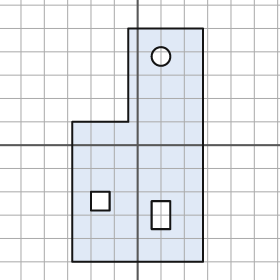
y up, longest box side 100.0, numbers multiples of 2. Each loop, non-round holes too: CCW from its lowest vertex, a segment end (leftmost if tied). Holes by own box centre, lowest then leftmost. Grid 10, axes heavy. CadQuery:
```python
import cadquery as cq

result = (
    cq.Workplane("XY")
    .moveTo(-28.0, -50.0)
    .lineTo(28.0, -50.0)
    .lineTo(28.0, 50.0)
    .lineTo(-4.0, 50.0)
    .lineTo(-4.0, 10.0)
    .lineTo(-28.0, 10.0)
    .close()
    .moveTo(6.0, -36.0)
    .lineTo(14.0, -36.0)
    .lineTo(14.0, -24.0)
    .lineTo(6.0, -24.0)
    .close()
    .moveTo(-20.0, -28.0)
    .lineTo(-12.0, -28.0)
    .lineTo(-12.0, -20.0)
    .lineTo(-20.0, -20.0)
    .close()
    .moveTo(10.0, 38.0)
    .circle(4.0)
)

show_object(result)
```